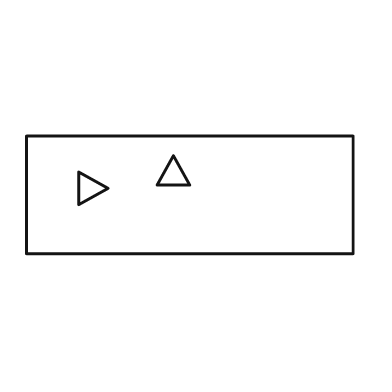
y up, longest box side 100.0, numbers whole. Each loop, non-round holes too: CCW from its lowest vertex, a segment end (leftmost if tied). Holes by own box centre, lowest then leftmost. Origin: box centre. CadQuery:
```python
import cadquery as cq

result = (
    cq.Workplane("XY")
    .moveTo(-50.0, -18.0)
    .lineTo(50.0, -18.0)
    .lineTo(50.0, 18.0)
    .lineTo(-50.0, 18.0)
    .close()
    .moveTo(-34.0, -3.0)
    .lineTo(-25.0, 2.0)
    .lineTo(-34.0, 7.0)
    .close()
    .moveTo(-10.0, 3.0)
    .lineTo(0.0, 3.0)
    .lineTo(-5.0, 12.0)
    .close()
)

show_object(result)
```